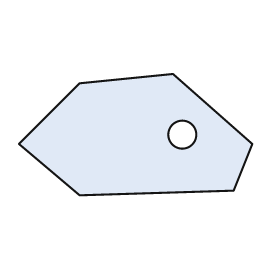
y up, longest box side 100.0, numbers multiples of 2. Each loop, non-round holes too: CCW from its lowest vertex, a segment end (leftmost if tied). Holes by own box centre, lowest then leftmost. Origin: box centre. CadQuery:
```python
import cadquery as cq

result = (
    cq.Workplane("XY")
    .moveTo(-24.0, -26.0)
    .lineTo(42.0, -24.0)
    .lineTo(50.0, -4.0)
    .lineTo(16.0, 26.0)
    .lineTo(-24.0, 22.0)
    .lineTo(-50.0, -4.0)
    .close()
    .moveTo(20.0, 0.0)
    .circle(6.0)
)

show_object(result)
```